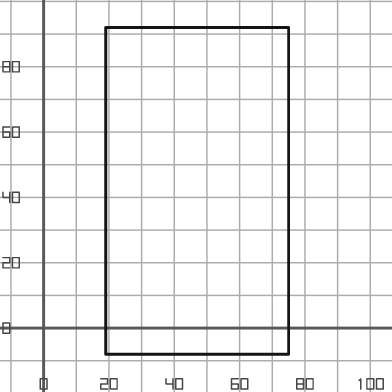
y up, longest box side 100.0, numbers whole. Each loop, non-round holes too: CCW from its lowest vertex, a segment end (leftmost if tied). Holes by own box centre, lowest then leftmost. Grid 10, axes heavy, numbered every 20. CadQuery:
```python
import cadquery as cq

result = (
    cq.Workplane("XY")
    .moveTo(19.0, -8.0)
    .lineTo(75.0, -8.0)
    .lineTo(75.0, 92.0)
    .lineTo(19.0, 92.0)
    .close()
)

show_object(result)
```